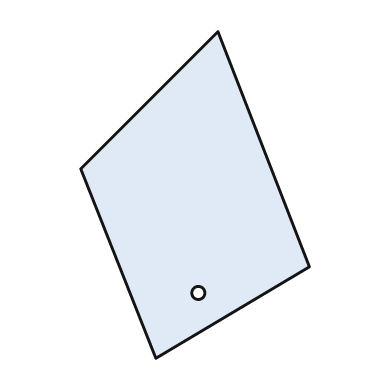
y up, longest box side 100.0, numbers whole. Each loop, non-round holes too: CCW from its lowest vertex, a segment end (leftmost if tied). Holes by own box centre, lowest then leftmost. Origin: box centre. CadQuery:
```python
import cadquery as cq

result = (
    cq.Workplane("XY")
    .moveTo(-12.0, -50.0)
    .lineTo(35.0, -22.0)
    .lineTo(7.0, 50.0)
    .lineTo(-35.0, 8.0)
    .close()
    .moveTo(1.0, -30.0)
    .circle(2.0)
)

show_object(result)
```